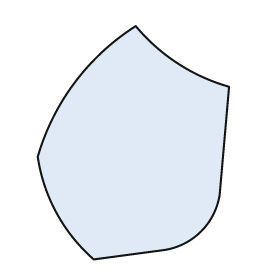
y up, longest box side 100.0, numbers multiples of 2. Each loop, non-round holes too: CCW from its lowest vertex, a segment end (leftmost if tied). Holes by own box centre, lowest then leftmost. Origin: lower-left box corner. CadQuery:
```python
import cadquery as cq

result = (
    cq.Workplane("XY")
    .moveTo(24.0, 0.0)
    .lineTo(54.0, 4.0)
    .threePointArc((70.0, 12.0), (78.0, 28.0))
    .lineTo(82.0, 74.0)
    .threePointArc((60.0, 84.0), (42.0, 100.0))
    .threePointArc((16.0, 76.0), (0.0, 44.0))
    .threePointArc((8.0, 20.0), (24.0, 0.0))
    .close()
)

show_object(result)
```